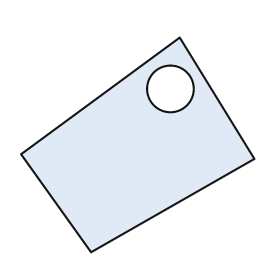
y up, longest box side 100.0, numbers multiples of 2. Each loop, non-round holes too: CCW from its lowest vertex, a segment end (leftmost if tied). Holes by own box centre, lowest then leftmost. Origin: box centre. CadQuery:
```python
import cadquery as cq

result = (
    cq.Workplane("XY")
    .moveTo(-20.0, -46.0)
    .lineTo(50.0, -6.0)
    .lineTo(18.0, 46.0)
    .lineTo(-50.0, -4.0)
    .close()
    .moveTo(14.0, 24.0)
    .circle(10.0)
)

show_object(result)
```